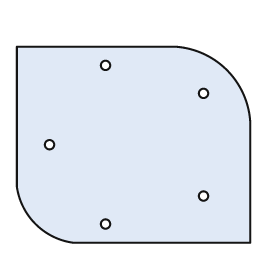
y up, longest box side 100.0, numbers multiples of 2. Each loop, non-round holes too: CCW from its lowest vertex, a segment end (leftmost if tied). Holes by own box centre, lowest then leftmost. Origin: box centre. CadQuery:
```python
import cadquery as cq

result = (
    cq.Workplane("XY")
    .moveTo(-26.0, -42.0)
    .lineTo(50.0, -42.0)
    .lineTo(50.0, 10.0)
    .threePointArc((40.0, 32.0), (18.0, 42.0))
    .lineTo(-50.0, 42.0)
    .lineTo(-50.0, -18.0)
    .threePointArc((-42.0, -34.0), (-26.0, -42.0))
    .close()
    .moveTo(-12.0, -34.0)
    .circle(2.0)
    .moveTo(30.0, -22.0)
    .circle(2.0)
    .moveTo(-36.0, 0.0)
    .circle(2.0)
    .moveTo(30.0, 22.0)
    .circle(2.0)
    .moveTo(-12.0, 34.0)
    .circle(2.0)
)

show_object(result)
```